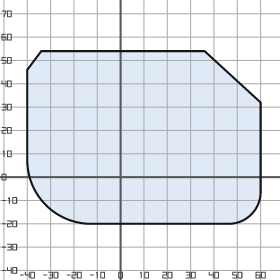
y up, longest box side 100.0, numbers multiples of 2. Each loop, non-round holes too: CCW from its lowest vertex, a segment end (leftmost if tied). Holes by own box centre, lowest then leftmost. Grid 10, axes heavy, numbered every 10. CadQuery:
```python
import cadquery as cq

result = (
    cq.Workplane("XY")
    .moveTo(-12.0, -20.0)
    .lineTo(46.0, -20.0)
    .threePointArc((56.0, -16.0), (60.0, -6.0))
    .lineTo(60.0, 32.0)
    .lineTo(36.0, 54.0)
    .lineTo(-34.0, 54.0)
    .lineTo(-40.0, 46.0)
    .lineTo(-40.0, 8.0)
    .threePointArc((-32.0, -12.0), (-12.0, -20.0))
    .close()
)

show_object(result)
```